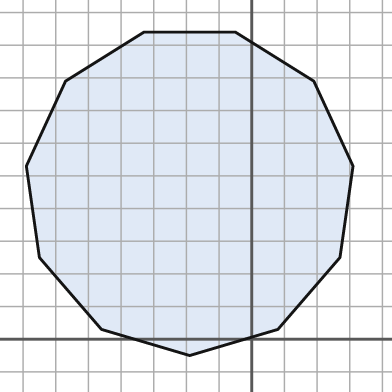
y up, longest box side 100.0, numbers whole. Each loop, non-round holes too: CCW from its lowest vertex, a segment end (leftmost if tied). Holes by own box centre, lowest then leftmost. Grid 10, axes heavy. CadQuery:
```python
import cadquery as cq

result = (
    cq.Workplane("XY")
    .moveTo(-19.0, -5.0)
    .lineTo(8.0, 3.0)
    .lineTo(27.0, 25.0)
    .lineTo(31.0, 53.0)
    .lineTo(19.0, 79.0)
    .lineTo(-5.0, 94.0)
    .lineTo(-33.0, 94.0)
    .lineTo(-57.0, 79.0)
    .lineTo(-69.0, 53.0)
    .lineTo(-65.0, 25.0)
    .lineTo(-46.0, 3.0)
    .close()
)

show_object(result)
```